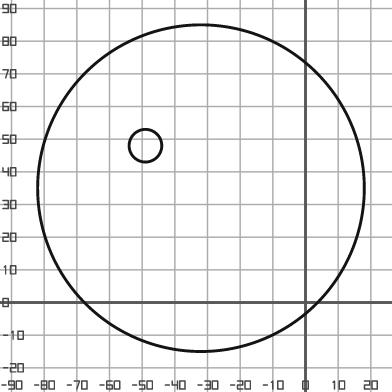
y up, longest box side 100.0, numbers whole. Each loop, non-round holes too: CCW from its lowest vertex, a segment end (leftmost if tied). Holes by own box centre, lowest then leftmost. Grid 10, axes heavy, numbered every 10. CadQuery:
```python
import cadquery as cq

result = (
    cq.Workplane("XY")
    .moveTo(-32.0, 35.0)
    .circle(50.0)
    .moveTo(-49.0, 48.0)
    .circle(5.0)
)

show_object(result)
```